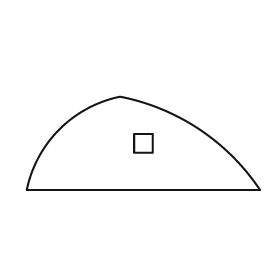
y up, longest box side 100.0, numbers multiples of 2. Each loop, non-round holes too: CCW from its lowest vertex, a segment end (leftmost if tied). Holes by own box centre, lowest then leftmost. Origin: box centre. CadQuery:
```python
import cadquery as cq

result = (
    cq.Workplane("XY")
    .moveTo(-50.0, -20.0)
    .lineTo(50.0, -20.0)
    .threePointArc((24.0, 6.0), (-10.0, 20.0))
    .threePointArc((-36.0, 6.0), (-50.0, -20.0))
    .close()
    .moveTo(-4.0, -4.0)
    .lineTo(4.0, -4.0)
    .lineTo(4.0, 4.0)
    .lineTo(-4.0, 4.0)
    .close()
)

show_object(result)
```